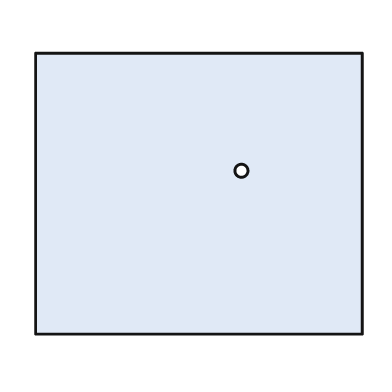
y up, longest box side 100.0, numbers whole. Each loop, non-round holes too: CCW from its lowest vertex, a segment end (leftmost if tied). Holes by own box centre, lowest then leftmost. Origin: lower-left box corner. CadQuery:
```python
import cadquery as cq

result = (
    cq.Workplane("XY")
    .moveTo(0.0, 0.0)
    .lineTo(100.0, 0.0)
    .lineTo(100.0, 86.0)
    .lineTo(0.0, 86.0)
    .close()
    .moveTo(63.0, 50.0)
    .circle(2.0)
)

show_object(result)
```